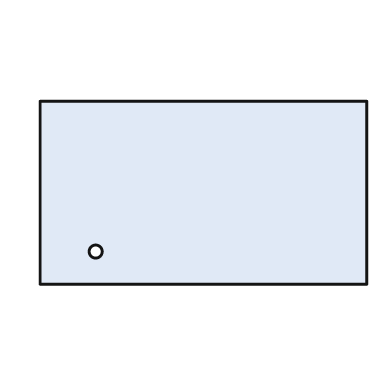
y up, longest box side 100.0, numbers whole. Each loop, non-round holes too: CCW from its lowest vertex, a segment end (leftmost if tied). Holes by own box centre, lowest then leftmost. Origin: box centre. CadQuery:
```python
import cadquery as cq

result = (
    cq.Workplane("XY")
    .moveTo(-50.0, -28.0)
    .lineTo(50.0, -28.0)
    .lineTo(50.0, 28.0)
    .lineTo(-50.0, 28.0)
    .close()
    .moveTo(-33.0, -18.0)
    .circle(2.0)
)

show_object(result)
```